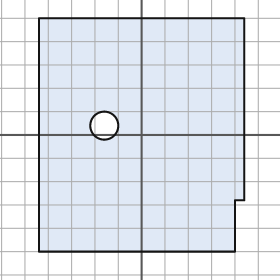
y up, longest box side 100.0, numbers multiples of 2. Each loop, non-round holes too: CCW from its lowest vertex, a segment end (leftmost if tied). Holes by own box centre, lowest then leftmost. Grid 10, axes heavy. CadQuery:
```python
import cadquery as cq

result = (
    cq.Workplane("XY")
    .moveTo(-44.0, -50.0)
    .lineTo(40.0, -50.0)
    .lineTo(40.0, -28.0)
    .lineTo(44.0, -28.0)
    .lineTo(44.0, 50.0)
    .lineTo(-44.0, 50.0)
    .close()
    .moveTo(-16.0, 4.0)
    .circle(6.0)
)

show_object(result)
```